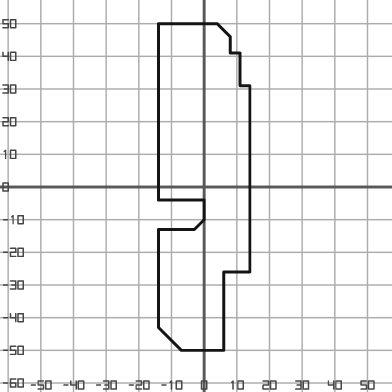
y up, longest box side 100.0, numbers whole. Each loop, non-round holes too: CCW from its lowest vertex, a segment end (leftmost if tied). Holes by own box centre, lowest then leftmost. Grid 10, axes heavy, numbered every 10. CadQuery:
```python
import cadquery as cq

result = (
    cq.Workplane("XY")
    .moveTo(-7.0, -50.0)
    .lineTo(6.0, -50.0)
    .lineTo(6.0, -26.0)
    .lineTo(14.0, -26.0)
    .lineTo(14.0, 31.0)
    .lineTo(11.0, 31.0)
    .lineTo(11.0, 41.0)
    .lineTo(8.0, 41.0)
    .lineTo(8.0, 46.0)
    .lineTo(4.0, 50.0)
    .lineTo(-14.0, 50.0)
    .lineTo(-14.0, -4.0)
    .lineTo(0.0, -4.0)
    .lineTo(0.0, -10.0)
    .lineTo(-3.0, -13.0)
    .lineTo(-14.0, -13.0)
    .lineTo(-14.0, -43.0)
    .close()
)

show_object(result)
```